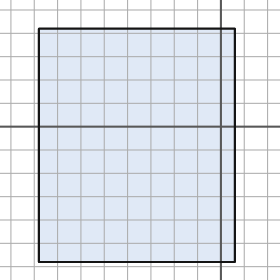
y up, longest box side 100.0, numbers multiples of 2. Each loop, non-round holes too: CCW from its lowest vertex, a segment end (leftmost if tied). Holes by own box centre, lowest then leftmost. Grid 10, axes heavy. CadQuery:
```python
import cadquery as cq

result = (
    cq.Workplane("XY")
    .moveTo(-78.0, -58.0)
    .lineTo(6.0, -58.0)
    .lineTo(6.0, 42.0)
    .lineTo(-78.0, 42.0)
    .close()
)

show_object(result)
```